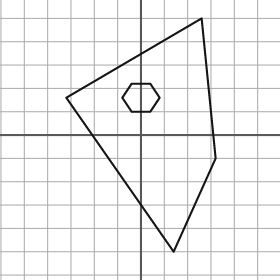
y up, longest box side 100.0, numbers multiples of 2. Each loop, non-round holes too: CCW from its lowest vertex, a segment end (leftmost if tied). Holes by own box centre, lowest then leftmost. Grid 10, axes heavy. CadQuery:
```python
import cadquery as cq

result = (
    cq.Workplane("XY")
    .moveTo(14.0, -50.0)
    .lineTo(32.0, -10.0)
    .lineTo(26.0, 50.0)
    .lineTo(-32.0, 16.0)
    .close()
    .moveTo(-4.0, 10.0)
    .lineTo(4.0, 10.0)
    .lineTo(8.0, 16.0)
    .lineTo(4.0, 22.0)
    .lineTo(-4.0, 22.0)
    .lineTo(-8.0, 16.0)
    .close()
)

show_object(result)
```